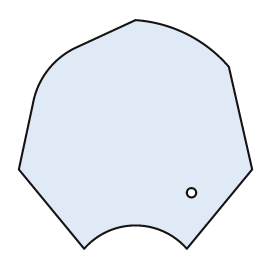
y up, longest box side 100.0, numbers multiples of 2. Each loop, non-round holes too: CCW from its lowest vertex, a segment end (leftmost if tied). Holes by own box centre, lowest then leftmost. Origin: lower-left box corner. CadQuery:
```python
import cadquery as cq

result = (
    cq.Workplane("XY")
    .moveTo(28.0, 0.0)
    .threePointArc((50.0, 10.0), (72.0, 0.0))
    .lineTo(100.0, 34.0)
    .lineTo(90.0, 78.0)
    .threePointArc((72.0, 92.0), (50.0, 98.0))
    .lineTo(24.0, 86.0)
    .threePointArc((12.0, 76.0), (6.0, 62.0))
    .lineTo(0.0, 34.0)
    .close()
    .moveTo(74.0, 24.0)
    .circle(2.0)
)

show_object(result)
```